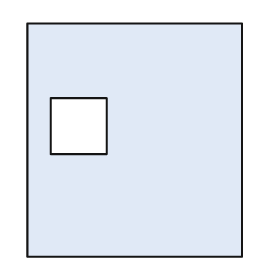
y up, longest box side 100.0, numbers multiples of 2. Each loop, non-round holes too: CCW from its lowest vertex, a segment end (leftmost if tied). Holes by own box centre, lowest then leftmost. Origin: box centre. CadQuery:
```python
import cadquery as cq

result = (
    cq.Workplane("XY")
    .moveTo(-46.0, -50.0)
    .lineTo(46.0, -50.0)
    .lineTo(46.0, 50.0)
    .lineTo(-46.0, 50.0)
    .close()
    .moveTo(-36.0, -6.0)
    .lineTo(-12.0, -6.0)
    .lineTo(-12.0, 18.0)
    .lineTo(-36.0, 18.0)
    .close()
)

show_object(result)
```